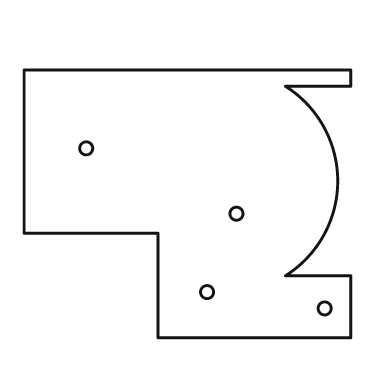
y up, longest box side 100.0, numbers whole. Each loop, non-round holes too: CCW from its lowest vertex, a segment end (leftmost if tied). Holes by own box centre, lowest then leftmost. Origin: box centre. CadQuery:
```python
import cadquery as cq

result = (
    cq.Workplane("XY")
    .moveTo(-9.0, -41.0)
    .lineTo(50.0, -41.0)
    .lineTo(50.0, -22.0)
    .lineTo(30.0, -22.0)
    .threePointArc((46.0, 7.0), (30.0, 36.0))
    .lineTo(50.0, 36.0)
    .lineTo(50.0, 41.0)
    .lineTo(-50.0, 41.0)
    .lineTo(-50.0, -9.0)
    .lineTo(-9.0, -9.0)
    .close()
    .moveTo(42.0, -32.0)
    .circle(2.0)
    .moveTo(6.0, -27.0)
    .circle(2.0)
    .moveTo(15.0, -3.0)
    .circle(2.0)
    .moveTo(-31.0, 17.0)
    .circle(2.0)
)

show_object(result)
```